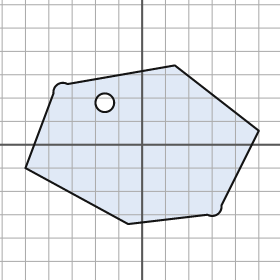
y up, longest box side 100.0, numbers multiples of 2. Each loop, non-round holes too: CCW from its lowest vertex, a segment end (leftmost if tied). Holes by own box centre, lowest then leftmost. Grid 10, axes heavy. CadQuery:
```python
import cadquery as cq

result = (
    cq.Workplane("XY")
    .moveTo(-6.0, -34.0)
    .lineTo(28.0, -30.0)
    .threePointArc((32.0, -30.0), (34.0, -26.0))
    .lineTo(50.0, 6.0)
    .lineTo(14.0, 34.0)
    .lineTo(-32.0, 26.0)
    .threePointArc((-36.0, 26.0), (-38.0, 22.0))
    .lineTo(-50.0, -10.0)
    .close()
    .moveTo(-16.0, 18.0)
    .circle(4.0)
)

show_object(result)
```